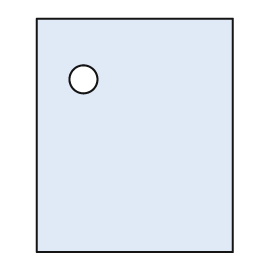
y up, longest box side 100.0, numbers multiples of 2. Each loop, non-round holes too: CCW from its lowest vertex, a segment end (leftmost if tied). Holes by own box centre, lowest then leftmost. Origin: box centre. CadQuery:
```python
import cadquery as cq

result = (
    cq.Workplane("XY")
    .moveTo(-42.0, -50.0)
    .lineTo(42.0, -50.0)
    .lineTo(42.0, 50.0)
    .lineTo(-42.0, 50.0)
    .close()
    .moveTo(-22.0, 24.0)
    .circle(6.0)
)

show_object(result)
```